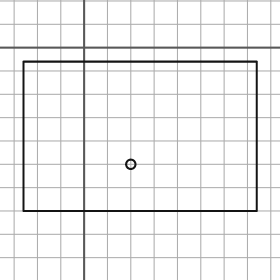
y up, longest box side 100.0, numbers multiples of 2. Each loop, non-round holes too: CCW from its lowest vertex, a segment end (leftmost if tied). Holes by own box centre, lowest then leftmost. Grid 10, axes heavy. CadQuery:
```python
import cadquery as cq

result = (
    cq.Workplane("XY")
    .moveTo(-26.0, -70.0)
    .lineTo(74.0, -70.0)
    .lineTo(74.0, -6.0)
    .lineTo(-26.0, -6.0)
    .close()
    .moveTo(20.0, -50.0)
    .circle(2.0)
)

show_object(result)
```